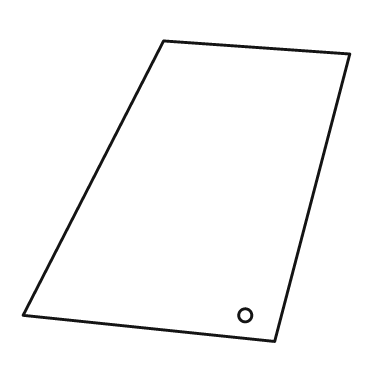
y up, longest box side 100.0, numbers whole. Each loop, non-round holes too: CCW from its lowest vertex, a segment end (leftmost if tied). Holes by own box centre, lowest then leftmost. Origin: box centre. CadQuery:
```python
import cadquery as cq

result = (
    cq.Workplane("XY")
    .moveTo(27.0, -46.0)
    .lineTo(50.0, 42.0)
    .lineTo(-7.0, 46.0)
    .lineTo(-50.0, -38.0)
    .close()
    .moveTo(18.0, -38.0)
    .circle(2.0)
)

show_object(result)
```